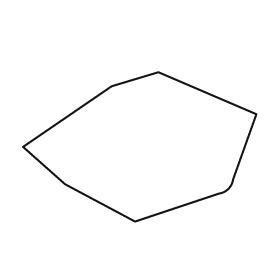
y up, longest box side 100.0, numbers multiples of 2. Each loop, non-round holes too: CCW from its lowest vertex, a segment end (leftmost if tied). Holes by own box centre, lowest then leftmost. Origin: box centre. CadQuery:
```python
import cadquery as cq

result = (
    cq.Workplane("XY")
    .moveTo(-2.0, -32.0)
    .lineTo(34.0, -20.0)
    .threePointArc((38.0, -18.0), (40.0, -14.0))
    .lineTo(50.0, 14.0)
    .lineTo(8.0, 32.0)
    .lineTo(-12.0, 26.0)
    .lineTo(-50.0, 0.0)
    .lineTo(-32.0, -16.0)
    .close()
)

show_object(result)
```